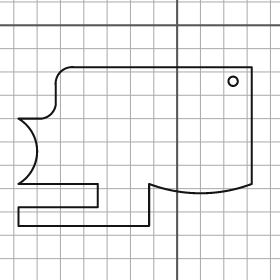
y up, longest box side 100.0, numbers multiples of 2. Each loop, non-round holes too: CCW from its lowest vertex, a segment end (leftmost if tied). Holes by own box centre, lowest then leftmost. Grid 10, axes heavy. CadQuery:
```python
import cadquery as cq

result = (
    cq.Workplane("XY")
    .moveTo(-68.0, -86.0)
    .lineTo(-12.0, -86.0)
    .lineTo(-12.0, -68.0)
    .threePointArc((10.0, -72.0), (32.0, -68.0))
    .lineTo(32.0, -18.0)
    .lineTo(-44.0, -18.0)
    .threePointArc((-50.0, -20.0), (-52.0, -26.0))
    .lineTo(-52.0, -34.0)
    .threePointArc((-54.0, -38.0), (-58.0, -40.0))
    .lineTo(-68.0, -40.0)
    .threePointArc((-60.0, -54.0), (-68.0, -68.0))
    .lineTo(-34.0, -68.0)
    .lineTo(-34.0, -78.0)
    .lineTo(-68.0, -78.0)
    .close()
    .moveTo(24.0, -24.0)
    .circle(2.0)
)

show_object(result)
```